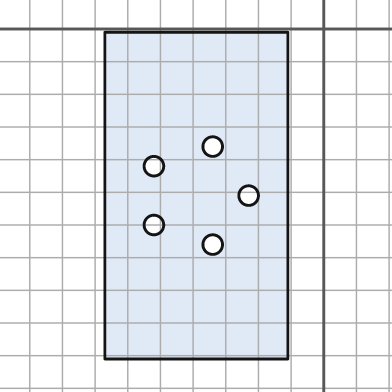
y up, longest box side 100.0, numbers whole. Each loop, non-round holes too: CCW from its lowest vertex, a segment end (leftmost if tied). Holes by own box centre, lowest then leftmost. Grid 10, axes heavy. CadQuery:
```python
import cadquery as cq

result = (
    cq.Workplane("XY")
    .moveTo(-67.0, -101.0)
    .lineTo(-11.0, -101.0)
    .lineTo(-11.0, -1.0)
    .lineTo(-67.0, -1.0)
    .close()
    .moveTo(-34.0, -66.0)
    .circle(3.0)
    .moveTo(-52.0, -60.0)
    .circle(3.0)
    .moveTo(-23.0, -51.0)
    .circle(3.0)
    .moveTo(-52.0, -42.0)
    .circle(3.0)
    .moveTo(-34.0, -36.0)
    .circle(3.0)
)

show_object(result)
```